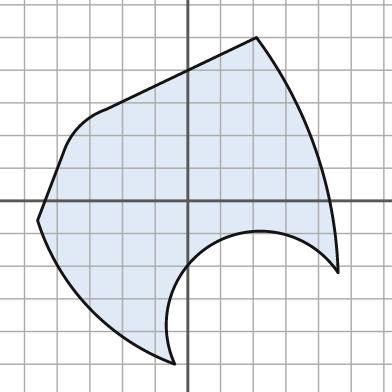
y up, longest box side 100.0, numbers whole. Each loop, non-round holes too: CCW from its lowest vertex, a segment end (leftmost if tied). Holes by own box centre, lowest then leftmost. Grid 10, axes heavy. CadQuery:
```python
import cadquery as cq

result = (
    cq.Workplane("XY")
    .moveTo(-4.0, -50.0)
    .threePointArc((8.0, -13.0), (46.0, -22.0))
    .threePointArc((39.0, 16.0), (21.0, 50.0))
    .lineTo(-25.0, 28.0)
    .threePointArc((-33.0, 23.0), (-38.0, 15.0))
    .lineTo(-46.0, -6.0)
    .threePointArc((-30.0, -33.0), (-4.0, -50.0))
    .close()
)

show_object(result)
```